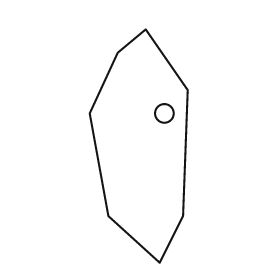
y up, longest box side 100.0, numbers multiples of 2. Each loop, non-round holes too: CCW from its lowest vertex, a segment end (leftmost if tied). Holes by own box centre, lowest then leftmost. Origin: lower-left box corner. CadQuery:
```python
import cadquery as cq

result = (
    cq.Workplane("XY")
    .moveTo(30.0, 0.0)
    .lineTo(40.0, 20.0)
    .lineTo(42.0, 74.0)
    .lineTo(24.0, 100.0)
    .lineTo(12.0, 90.0)
    .lineTo(0.0, 64.0)
    .lineTo(8.0, 20.0)
    .close()
    .moveTo(32.0, 64.0)
    .circle(4.0)
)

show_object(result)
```